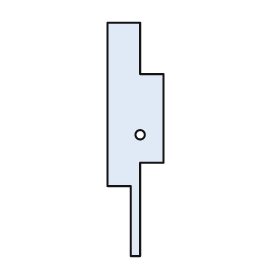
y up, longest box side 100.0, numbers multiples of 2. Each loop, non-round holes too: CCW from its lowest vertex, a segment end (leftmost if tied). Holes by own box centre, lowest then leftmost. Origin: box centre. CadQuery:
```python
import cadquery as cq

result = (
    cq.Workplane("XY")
    .moveTo(-2.0, -50.0)
    .lineTo(2.0, -50.0)
    .lineTo(2.0, -10.0)
    .lineTo(12.0, -10.0)
    .lineTo(12.0, 28.0)
    .lineTo(2.0, 28.0)
    .lineTo(2.0, 50.0)
    .lineTo(-12.0, 50.0)
    .lineTo(-12.0, -20.0)
    .lineTo(-2.0, -20.0)
    .close()
    .moveTo(2.0, 2.0)
    .circle(2.0)
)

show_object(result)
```